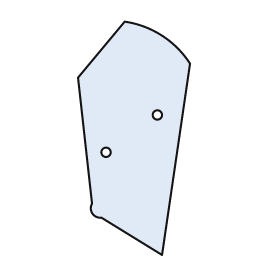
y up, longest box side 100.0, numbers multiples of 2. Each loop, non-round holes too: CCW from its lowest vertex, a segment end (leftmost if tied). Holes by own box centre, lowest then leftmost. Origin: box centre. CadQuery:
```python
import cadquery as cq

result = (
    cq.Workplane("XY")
    .moveTo(12.0, -50.0)
    .lineTo(24.0, 32.0)
    .threePointArc((12.0, 44.0), (-4.0, 50.0))
    .lineTo(-24.0, 26.0)
    .lineTo(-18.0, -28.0)
    .threePointArc((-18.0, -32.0), (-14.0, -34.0))
    .close()
    .moveTo(-12.0, -6.0)
    .circle(2.0)
    .moveTo(10.0, 10.0)
    .circle(2.0)
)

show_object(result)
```